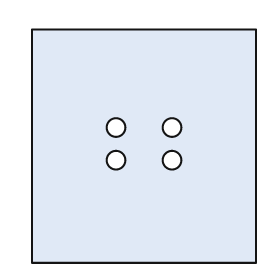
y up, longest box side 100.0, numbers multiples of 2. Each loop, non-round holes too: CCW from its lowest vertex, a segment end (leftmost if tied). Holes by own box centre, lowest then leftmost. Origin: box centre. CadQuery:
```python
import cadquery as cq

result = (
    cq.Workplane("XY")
    .moveTo(-48.0, -50.0)
    .lineTo(48.0, -50.0)
    .lineTo(48.0, 50.0)
    .lineTo(-48.0, 50.0)
    .close()
    .moveTo(-12.0, -6.0)
    .circle(4.0)
    .moveTo(12.0, -6.0)
    .circle(4.0)
    .moveTo(-12.0, 8.0)
    .circle(4.0)
    .moveTo(12.0, 8.0)
    .circle(4.0)
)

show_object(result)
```